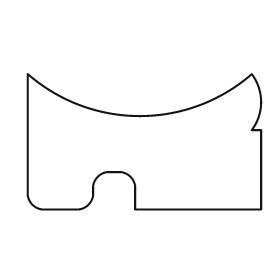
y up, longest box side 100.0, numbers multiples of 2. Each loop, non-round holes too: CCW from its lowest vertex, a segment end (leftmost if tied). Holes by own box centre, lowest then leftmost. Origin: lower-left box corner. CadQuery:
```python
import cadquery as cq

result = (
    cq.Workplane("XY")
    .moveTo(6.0, 0.0)
    .lineTo(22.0, 0.0)
    .threePointArc((26.0, 2.0), (28.0, 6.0))
    .lineTo(28.0, 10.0)
    .threePointArc((30.0, 14.0), (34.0, 16.0))
    .lineTo(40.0, 16.0)
    .threePointArc((44.0, 14.0), (46.0, 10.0))
    .lineTo(46.0, 0.0)
    .lineTo(100.0, 0.0)
    .lineTo(100.0, 34.0)
    .lineTo(96.0, 34.0)
    .threePointArc((100.0, 46.0), (96.0, 58.0))
    .threePointArc((48.0, 40.0), (0.0, 58.0))
    .lineTo(0.0, 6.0)
    .threePointArc((2.0, 2.0), (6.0, 0.0))
    .close()
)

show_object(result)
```